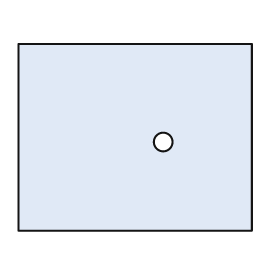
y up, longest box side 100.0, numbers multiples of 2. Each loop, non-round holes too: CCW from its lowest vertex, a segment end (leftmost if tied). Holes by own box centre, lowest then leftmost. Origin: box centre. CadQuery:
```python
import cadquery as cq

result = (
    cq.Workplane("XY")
    .moveTo(-50.0, -40.0)
    .lineTo(50.0, -40.0)
    .lineTo(50.0, 40.0)
    .lineTo(-50.0, 40.0)
    .close()
    .moveTo(12.0, -2.0)
    .circle(4.0)
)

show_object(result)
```